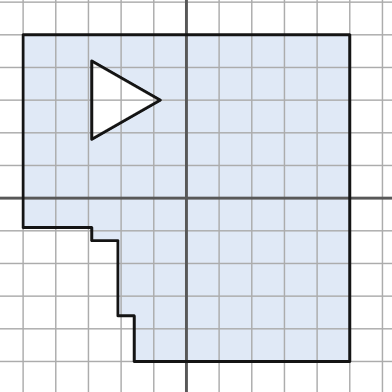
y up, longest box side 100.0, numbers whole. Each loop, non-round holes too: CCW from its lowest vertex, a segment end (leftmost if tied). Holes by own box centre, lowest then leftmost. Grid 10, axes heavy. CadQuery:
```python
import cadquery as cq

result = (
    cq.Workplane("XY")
    .moveTo(-16.0, -50.0)
    .lineTo(50.0, -50.0)
    .lineTo(50.0, 50.0)
    .lineTo(-50.0, 50.0)
    .lineTo(-50.0, -9.0)
    .lineTo(-29.0, -9.0)
    .lineTo(-29.0, -13.0)
    .lineTo(-21.0, -13.0)
    .lineTo(-21.0, -36.0)
    .lineTo(-16.0, -36.0)
    .close()
    .moveTo(-29.0, 18.0)
    .lineTo(-8.0, 30.0)
    .lineTo(-29.0, 42.0)
    .close()
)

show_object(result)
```